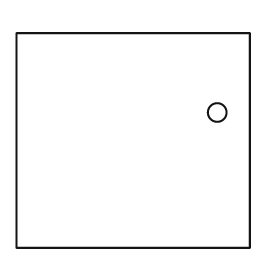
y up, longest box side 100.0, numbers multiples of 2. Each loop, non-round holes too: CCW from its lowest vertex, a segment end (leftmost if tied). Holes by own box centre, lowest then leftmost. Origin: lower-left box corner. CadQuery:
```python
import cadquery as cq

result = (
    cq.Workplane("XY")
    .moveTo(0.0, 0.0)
    .lineTo(100.0, 0.0)
    .lineTo(100.0, 92.0)
    .lineTo(0.0, 92.0)
    .close()
    .moveTo(86.0, 58.0)
    .circle(4.0)
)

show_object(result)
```